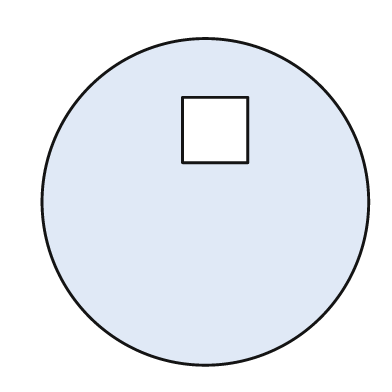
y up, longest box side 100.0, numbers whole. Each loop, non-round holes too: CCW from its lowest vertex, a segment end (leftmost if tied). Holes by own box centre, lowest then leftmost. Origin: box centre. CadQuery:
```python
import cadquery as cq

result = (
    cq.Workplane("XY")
    .moveTo(0.0, 0.0)
    .circle(50.0)
    .moveTo(-7.0, 12.0)
    .lineTo(13.0, 12.0)
    .lineTo(13.0, 32.0)
    .lineTo(-7.0, 32.0)
    .close()
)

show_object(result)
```